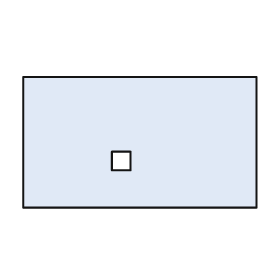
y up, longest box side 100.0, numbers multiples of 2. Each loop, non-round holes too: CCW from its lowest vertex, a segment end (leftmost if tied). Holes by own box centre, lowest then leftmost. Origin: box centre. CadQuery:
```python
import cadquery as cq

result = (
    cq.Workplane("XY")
    .moveTo(-50.0, -28.0)
    .lineTo(50.0, -28.0)
    .lineTo(50.0, 28.0)
    .lineTo(-50.0, 28.0)
    .close()
    .moveTo(-12.0, -12.0)
    .lineTo(-4.0, -12.0)
    .lineTo(-4.0, -4.0)
    .lineTo(-12.0, -4.0)
    .close()
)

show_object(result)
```